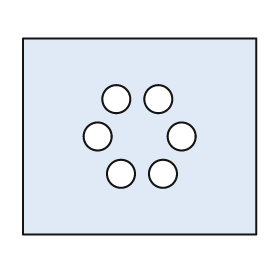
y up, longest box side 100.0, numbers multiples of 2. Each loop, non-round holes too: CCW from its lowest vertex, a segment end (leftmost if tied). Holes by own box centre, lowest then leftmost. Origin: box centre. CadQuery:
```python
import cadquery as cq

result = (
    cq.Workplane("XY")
    .moveTo(-50.0, -42.0)
    .lineTo(50.0, -42.0)
    .lineTo(50.0, 42.0)
    .lineTo(-50.0, 42.0)
    .close()
    .moveTo(-8.0, -16.0)
    .circle(6.0)
    .moveTo(10.0, -16.0)
    .circle(6.0)
    .moveTo(-18.0, 0.0)
    .circle(6.0)
    .moveTo(18.0, 0.0)
    .circle(6.0)
    .moveTo(-10.0, 16.0)
    .circle(6.0)
    .moveTo(8.0, 16.0)
    .circle(6.0)
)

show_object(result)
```